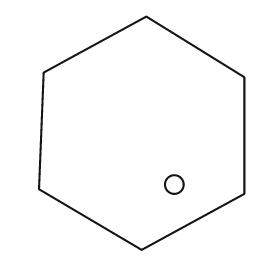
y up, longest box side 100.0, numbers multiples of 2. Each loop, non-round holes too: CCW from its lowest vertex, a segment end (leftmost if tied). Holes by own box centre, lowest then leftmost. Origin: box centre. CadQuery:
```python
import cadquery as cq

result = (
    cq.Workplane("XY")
    .moveTo(0.0, -50.0)
    .lineTo(44.0, -26.0)
    .lineTo(44.0, 24.0)
    .lineTo(2.0, 50.0)
    .lineTo(-42.0, 26.0)
    .lineTo(-44.0, -24.0)
    .close()
    .moveTo(14.0, -22.0)
    .circle(4.0)
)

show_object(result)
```